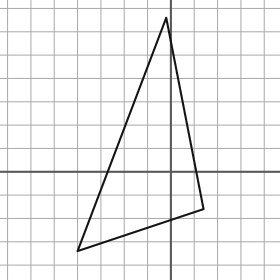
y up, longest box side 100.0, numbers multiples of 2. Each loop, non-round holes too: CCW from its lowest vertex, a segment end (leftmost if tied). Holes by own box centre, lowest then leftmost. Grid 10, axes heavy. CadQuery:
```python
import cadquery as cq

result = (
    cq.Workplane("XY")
    .moveTo(-40.0, -34.0)
    .lineTo(14.0, -16.0)
    .lineTo(-2.0, 66.0)
    .close()
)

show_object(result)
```